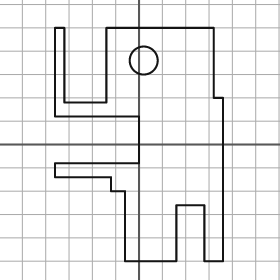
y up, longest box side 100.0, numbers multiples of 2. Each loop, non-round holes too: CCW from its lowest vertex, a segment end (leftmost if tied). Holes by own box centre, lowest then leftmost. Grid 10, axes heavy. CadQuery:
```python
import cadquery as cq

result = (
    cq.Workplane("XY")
    .moveTo(-6.0, -50.0)
    .lineTo(16.0, -50.0)
    .lineTo(16.0, -26.0)
    .lineTo(28.0, -26.0)
    .lineTo(28.0, -50.0)
    .lineTo(36.0, -50.0)
    .lineTo(36.0, 20.0)
    .lineTo(32.0, 20.0)
    .lineTo(32.0, 50.0)
    .lineTo(-14.0, 50.0)
    .lineTo(-14.0, 18.0)
    .lineTo(-32.0, 18.0)
    .lineTo(-32.0, 50.0)
    .lineTo(-36.0, 50.0)
    .lineTo(-36.0, 12.0)
    .lineTo(0.0, 12.0)
    .lineTo(0.0, -8.0)
    .lineTo(-36.0, -8.0)
    .lineTo(-36.0, -14.0)
    .lineTo(-12.0, -14.0)
    .lineTo(-12.0, -20.0)
    .lineTo(-6.0, -20.0)
    .close()
    .moveTo(2.0, 36.0)
    .circle(6.0)
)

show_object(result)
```